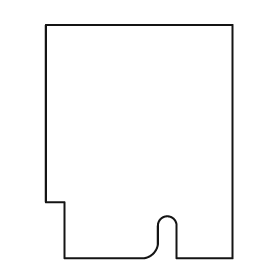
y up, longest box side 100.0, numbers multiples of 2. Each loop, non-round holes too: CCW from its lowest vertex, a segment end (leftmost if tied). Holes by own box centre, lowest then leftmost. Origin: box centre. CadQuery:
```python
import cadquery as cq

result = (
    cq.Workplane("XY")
    .moveTo(-32.0, -50.0)
    .lineTo(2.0, -50.0)
    .threePointArc((6.0, -48.0), (8.0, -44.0))
    .lineTo(8.0, -36.0)
    .threePointArc((12.0, -32.0), (16.0, -36.0))
    .lineTo(16.0, -50.0)
    .lineTo(40.0, -50.0)
    .lineTo(40.0, 50.0)
    .lineTo(-40.0, 50.0)
    .lineTo(-40.0, -26.0)
    .lineTo(-32.0, -26.0)
    .close()
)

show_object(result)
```